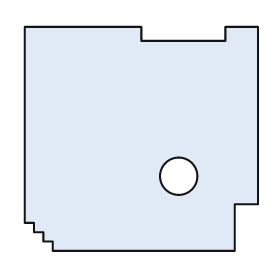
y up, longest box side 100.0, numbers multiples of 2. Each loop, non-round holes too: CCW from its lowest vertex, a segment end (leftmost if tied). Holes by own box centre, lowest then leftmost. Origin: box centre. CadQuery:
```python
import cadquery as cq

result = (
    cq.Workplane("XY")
    .moveTo(-38.0, -48.0)
    .lineTo(40.0, -48.0)
    .lineTo(40.0, -28.0)
    .lineTo(50.0, -28.0)
    .lineTo(50.0, 48.0)
    .lineTo(36.0, 48.0)
    .lineTo(36.0, 42.0)
    .lineTo(0.0, 42.0)
    .lineTo(0.0, 48.0)
    .lineTo(-50.0, 48.0)
    .lineTo(-50.0, -36.0)
    .lineTo(-46.0, -36.0)
    .lineTo(-46.0, -40.0)
    .lineTo(-42.0, -40.0)
    .lineTo(-42.0, -44.0)
    .lineTo(-38.0, -44.0)
    .close()
    .moveTo(16.0, -16.0)
    .circle(8.0)
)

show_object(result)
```